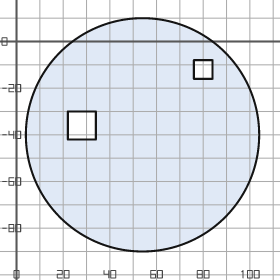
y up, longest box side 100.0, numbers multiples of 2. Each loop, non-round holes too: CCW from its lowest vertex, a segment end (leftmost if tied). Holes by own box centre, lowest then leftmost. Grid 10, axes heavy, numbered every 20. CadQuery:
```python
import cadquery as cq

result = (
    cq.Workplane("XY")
    .moveTo(54.0, -40.0)
    .circle(50.0)
    .moveTo(22.0, -42.0)
    .lineTo(34.0, -42.0)
    .lineTo(34.0, -30.0)
    .lineTo(22.0, -30.0)
    .close()
    .moveTo(76.0, -16.0)
    .lineTo(84.0, -16.0)
    .lineTo(84.0, -8.0)
    .lineTo(76.0, -8.0)
    .close()
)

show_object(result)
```